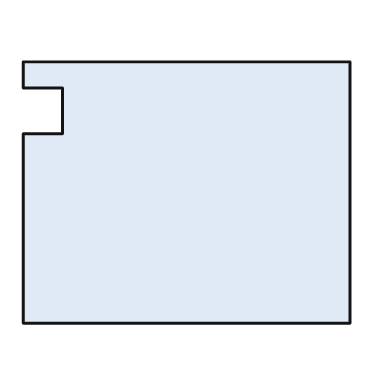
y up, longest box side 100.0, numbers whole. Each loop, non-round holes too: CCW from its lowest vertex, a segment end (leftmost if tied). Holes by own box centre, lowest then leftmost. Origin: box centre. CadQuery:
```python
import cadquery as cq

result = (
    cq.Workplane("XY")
    .moveTo(-50.0, -40.0)
    .lineTo(50.0, -40.0)
    .lineTo(50.0, 40.0)
    .lineTo(-50.0, 40.0)
    .lineTo(-50.0, 32.0)
    .lineTo(-38.0, 32.0)
    .lineTo(-38.0, 18.0)
    .lineTo(-50.0, 18.0)
    .close()
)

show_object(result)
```